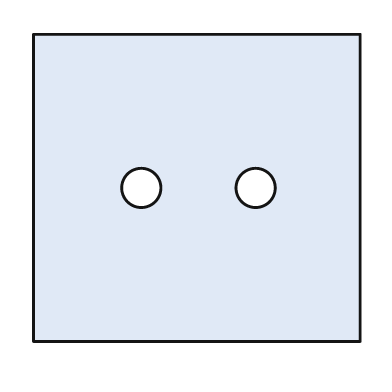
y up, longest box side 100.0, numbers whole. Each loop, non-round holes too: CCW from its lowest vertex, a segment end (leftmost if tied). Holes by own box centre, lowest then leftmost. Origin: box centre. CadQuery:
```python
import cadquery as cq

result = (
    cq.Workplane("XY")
    .moveTo(-50.0, -47.0)
    .lineTo(50.0, -47.0)
    .lineTo(50.0, 47.0)
    .lineTo(-50.0, 47.0)
    .close()
    .moveTo(-17.0, 0.0)
    .circle(6.0)
    .moveTo(18.0, 0.0)
    .circle(6.0)
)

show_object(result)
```